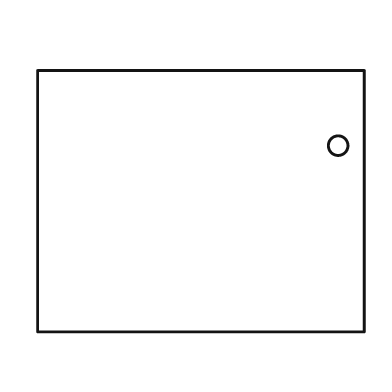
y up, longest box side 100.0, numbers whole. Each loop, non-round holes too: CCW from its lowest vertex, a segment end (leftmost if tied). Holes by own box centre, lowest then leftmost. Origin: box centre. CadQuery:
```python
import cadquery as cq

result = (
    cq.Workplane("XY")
    .moveTo(-50.0, -40.0)
    .lineTo(50.0, -40.0)
    .lineTo(50.0, 40.0)
    .lineTo(-50.0, 40.0)
    .close()
    .moveTo(42.0, 17.0)
    .circle(3.0)
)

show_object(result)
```